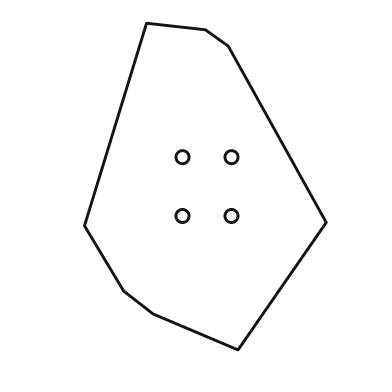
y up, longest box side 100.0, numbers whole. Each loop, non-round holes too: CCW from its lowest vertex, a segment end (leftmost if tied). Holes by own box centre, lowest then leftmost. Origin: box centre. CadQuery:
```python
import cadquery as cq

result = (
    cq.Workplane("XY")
    .moveTo(10.0, -50.0)
    .lineTo(37.0, -11.0)
    .lineTo(7.0, 43.0)
    .lineTo(0.0, 48.0)
    .lineTo(-18.0, 50.0)
    .lineTo(-37.0, -12.0)
    .lineTo(-25.0, -32.0)
    .lineTo(-16.0, -39.0)
    .close()
    .moveTo(-7.0, -9.0)
    .circle(2.0)
    .moveTo(8.0, -9.0)
    .circle(2.0)
    .moveTo(-7.0, 9.0)
    .circle(2.0)
    .moveTo(8.0, 9.0)
    .circle(2.0)
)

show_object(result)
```